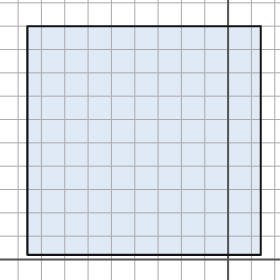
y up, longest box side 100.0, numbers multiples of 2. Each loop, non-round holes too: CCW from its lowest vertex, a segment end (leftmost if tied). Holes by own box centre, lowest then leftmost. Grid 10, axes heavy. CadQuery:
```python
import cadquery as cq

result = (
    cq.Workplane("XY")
    .moveTo(-86.0, 2.0)
    .lineTo(14.0, 2.0)
    .lineTo(14.0, 100.0)
    .lineTo(-86.0, 100.0)
    .close()
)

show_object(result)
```